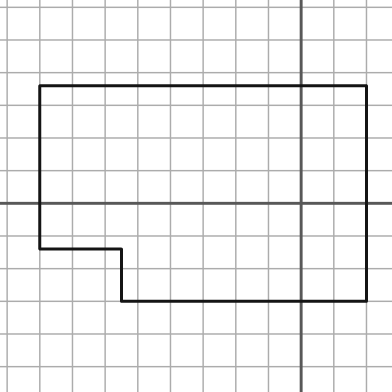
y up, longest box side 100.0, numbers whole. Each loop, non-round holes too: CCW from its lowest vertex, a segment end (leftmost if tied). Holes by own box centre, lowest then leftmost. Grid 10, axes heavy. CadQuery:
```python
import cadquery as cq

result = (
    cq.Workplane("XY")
    .moveTo(-55.0, -30.0)
    .lineTo(20.0, -30.0)
    .lineTo(20.0, 36.0)
    .lineTo(-80.0, 36.0)
    .lineTo(-80.0, -14.0)
    .lineTo(-55.0, -14.0)
    .close()
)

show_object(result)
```